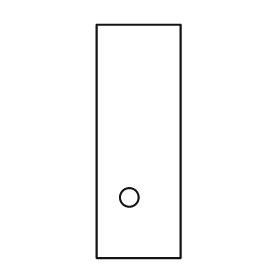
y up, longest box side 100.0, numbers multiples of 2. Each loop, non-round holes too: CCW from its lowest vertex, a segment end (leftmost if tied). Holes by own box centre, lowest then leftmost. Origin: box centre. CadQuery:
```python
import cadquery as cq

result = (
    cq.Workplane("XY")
    .moveTo(-18.0, -50.0)
    .lineTo(18.0, -50.0)
    .lineTo(18.0, 50.0)
    .lineTo(-18.0, 50.0)
    .close()
    .moveTo(-4.0, -24.0)
    .circle(4.0)
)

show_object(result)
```